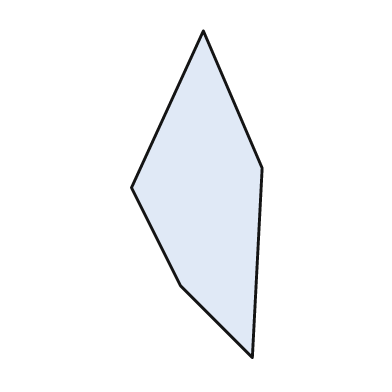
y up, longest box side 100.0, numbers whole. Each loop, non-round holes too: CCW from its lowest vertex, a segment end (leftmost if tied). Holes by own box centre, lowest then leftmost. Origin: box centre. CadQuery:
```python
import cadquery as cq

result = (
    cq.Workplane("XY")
    .moveTo(17.0, -50.0)
    .lineTo(20.0, 8.0)
    .lineTo(2.0, 50.0)
    .lineTo(-20.0, 2.0)
    .lineTo(-5.0, -28.0)
    .close()
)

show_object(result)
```